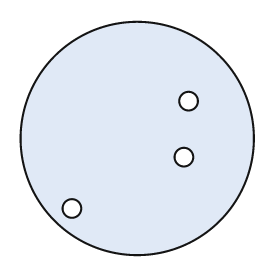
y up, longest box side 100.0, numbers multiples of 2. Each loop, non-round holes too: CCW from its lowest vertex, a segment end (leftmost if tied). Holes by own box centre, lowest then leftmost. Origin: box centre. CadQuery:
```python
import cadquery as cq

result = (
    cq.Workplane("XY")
    .moveTo(0.0, 0.0)
    .circle(50.0)
    .moveTo(-28.0, -30.0)
    .circle(4.0)
    .moveTo(20.0, -8.0)
    .circle(4.0)
    .moveTo(22.0, 16.0)
    .circle(4.0)
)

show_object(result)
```